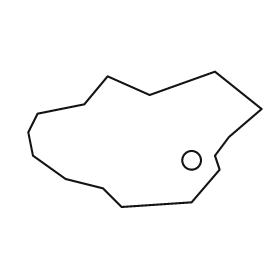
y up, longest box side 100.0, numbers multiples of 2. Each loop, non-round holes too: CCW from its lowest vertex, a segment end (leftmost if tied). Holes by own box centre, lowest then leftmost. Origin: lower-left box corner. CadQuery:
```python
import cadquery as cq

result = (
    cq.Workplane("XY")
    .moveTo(40.0, 0.0)
    .lineTo(70.0, 2.0)
    .lineTo(82.0, 16.0)
    .lineTo(80.0, 22.0)
    .lineTo(86.0, 30.0)
    .lineTo(100.0, 42.0)
    .lineTo(80.0, 58.0)
    .lineTo(52.0, 48.0)
    .lineTo(34.0, 56.0)
    .lineTo(24.0, 44.0)
    .lineTo(4.0, 40.0)
    .lineTo(0.0, 32.0)
    .lineTo(2.0, 22.0)
    .lineTo(16.0, 12.0)
    .lineTo(32.0, 8.0)
    .close()
    .moveTo(70.0, 20.0)
    .circle(4.0)
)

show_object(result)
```